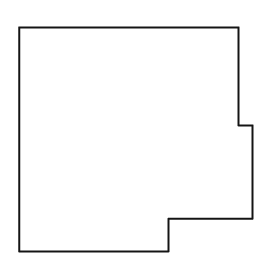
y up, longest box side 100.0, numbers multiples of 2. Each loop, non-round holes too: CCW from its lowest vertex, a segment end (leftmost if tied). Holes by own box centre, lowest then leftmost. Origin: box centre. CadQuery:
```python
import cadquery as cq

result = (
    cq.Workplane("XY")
    .moveTo(-50.0, -48.0)
    .lineTo(14.0, -48.0)
    .lineTo(14.0, -34.0)
    .lineTo(50.0, -34.0)
    .lineTo(50.0, 6.0)
    .lineTo(44.0, 6.0)
    .lineTo(44.0, 48.0)
    .lineTo(-50.0, 48.0)
    .close()
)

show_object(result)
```